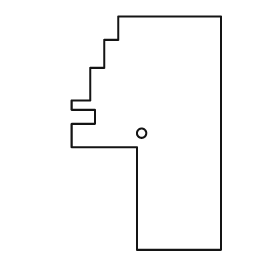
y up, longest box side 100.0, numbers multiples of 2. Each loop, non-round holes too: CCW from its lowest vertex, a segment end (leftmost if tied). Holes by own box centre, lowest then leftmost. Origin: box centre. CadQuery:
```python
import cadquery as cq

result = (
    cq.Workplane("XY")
    .moveTo(-4.0, -50.0)
    .lineTo(32.0, -50.0)
    .lineTo(32.0, 50.0)
    .lineTo(-12.0, 50.0)
    .lineTo(-12.0, 40.0)
    .lineTo(-18.0, 40.0)
    .lineTo(-18.0, 28.0)
    .lineTo(-24.0, 28.0)
    .lineTo(-24.0, 14.0)
    .lineTo(-32.0, 14.0)
    .lineTo(-32.0, 10.0)
    .lineTo(-22.0, 10.0)
    .lineTo(-22.0, 4.0)
    .lineTo(-32.0, 4.0)
    .lineTo(-32.0, -6.0)
    .lineTo(-4.0, -6.0)
    .close()
    .moveTo(-2.0, 0.0)
    .circle(2.0)
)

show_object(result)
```